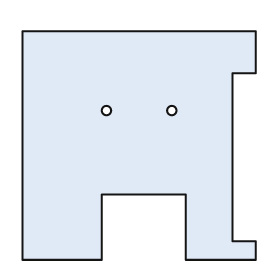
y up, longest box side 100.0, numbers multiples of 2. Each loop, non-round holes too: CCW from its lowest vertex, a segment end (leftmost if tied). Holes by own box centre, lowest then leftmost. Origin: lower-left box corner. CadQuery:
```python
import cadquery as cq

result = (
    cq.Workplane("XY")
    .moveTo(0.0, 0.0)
    .lineTo(34.0, 0.0)
    .lineTo(34.0, 28.0)
    .lineTo(70.0, 28.0)
    .lineTo(70.0, 0.0)
    .lineTo(100.0, 0.0)
    .lineTo(100.0, 8.0)
    .lineTo(90.0, 8.0)
    .lineTo(90.0, 80.0)
    .lineTo(100.0, 80.0)
    .lineTo(100.0, 98.0)
    .lineTo(0.0, 98.0)
    .close()
    .moveTo(36.0, 64.0)
    .circle(2.0)
    .moveTo(64.0, 64.0)
    .circle(2.0)
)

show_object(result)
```